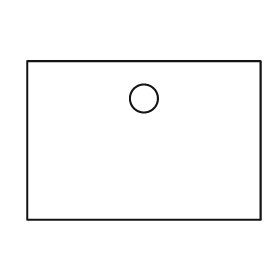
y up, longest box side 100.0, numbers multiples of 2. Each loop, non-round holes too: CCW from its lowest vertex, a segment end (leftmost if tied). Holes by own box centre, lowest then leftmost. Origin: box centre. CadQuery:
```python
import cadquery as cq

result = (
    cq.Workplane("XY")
    .moveTo(-50.0, -34.0)
    .lineTo(50.0, -34.0)
    .lineTo(50.0, 34.0)
    .lineTo(-50.0, 34.0)
    .close()
    .moveTo(0.0, 18.0)
    .circle(6.0)
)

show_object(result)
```